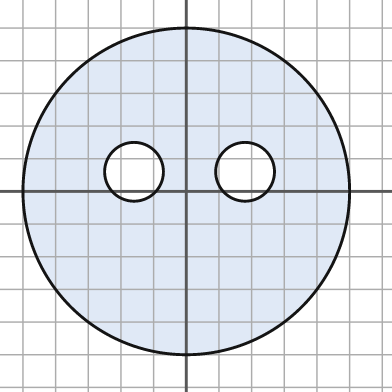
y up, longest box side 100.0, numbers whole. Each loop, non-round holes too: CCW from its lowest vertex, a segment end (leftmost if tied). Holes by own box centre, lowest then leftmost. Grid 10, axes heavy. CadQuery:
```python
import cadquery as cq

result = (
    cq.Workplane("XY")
    .moveTo(0.0, 0.0)
    .circle(50.0)
    .moveTo(-16.0, 6.0)
    .circle(9.0)
    .moveTo(18.0, 6.0)
    .circle(9.0)
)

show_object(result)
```